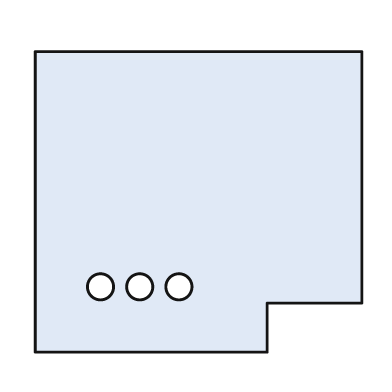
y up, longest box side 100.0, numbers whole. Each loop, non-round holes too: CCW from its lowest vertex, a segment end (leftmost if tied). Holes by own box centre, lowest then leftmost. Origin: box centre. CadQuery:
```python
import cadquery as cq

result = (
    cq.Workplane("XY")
    .moveTo(-50.0, -46.0)
    .lineTo(21.0, -46.0)
    .lineTo(21.0, -31.0)
    .lineTo(50.0, -31.0)
    .lineTo(50.0, 46.0)
    .lineTo(-50.0, 46.0)
    .close()
    .moveTo(-30.0, -26.0)
    .circle(4.0)
    .moveTo(-18.0, -26.0)
    .circle(4.0)
    .moveTo(-6.0, -26.0)
    .circle(4.0)
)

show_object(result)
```